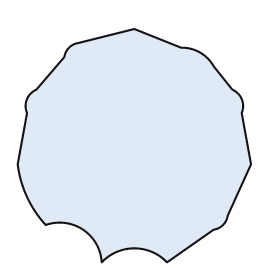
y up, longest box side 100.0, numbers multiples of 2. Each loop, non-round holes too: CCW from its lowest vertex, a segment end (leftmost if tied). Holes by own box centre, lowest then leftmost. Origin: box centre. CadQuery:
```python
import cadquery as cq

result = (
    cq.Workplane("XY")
    .moveTo(-14.0, -50.0)
    .threePointArc((0.0, -44.0), (14.0, -50.0))
    .lineTo(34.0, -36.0)
    .threePointArc((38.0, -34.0), (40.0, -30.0))
    .lineTo(50.0, -8.0)
    .lineTo(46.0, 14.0)
    .threePointArc((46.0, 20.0), (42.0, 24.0))
    .lineTo(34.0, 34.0)
    .threePointArc((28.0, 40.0), (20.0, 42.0))
    .lineTo(0.0, 50.0)
    .lineTo(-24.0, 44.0)
    .threePointArc((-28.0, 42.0), (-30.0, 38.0))
    .lineTo(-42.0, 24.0)
    .threePointArc((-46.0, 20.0), (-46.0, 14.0))
    .lineTo(-50.0, -8.0)
    .threePointArc((-46.0, -22.0), (-38.0, -34.0))
    .threePointArc((-22.0, -36.0), (-14.0, -50.0))
    .close()
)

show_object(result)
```